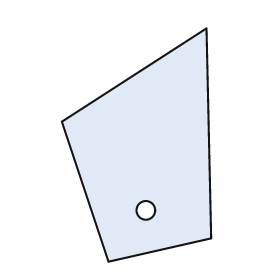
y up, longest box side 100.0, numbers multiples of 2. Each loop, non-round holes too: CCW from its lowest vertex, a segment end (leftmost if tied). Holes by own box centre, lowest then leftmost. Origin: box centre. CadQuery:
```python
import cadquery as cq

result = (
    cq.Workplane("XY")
    .moveTo(-12.0, -50.0)
    .lineTo(32.0, -40.0)
    .lineTo(30.0, 50.0)
    .lineTo(-32.0, 10.0)
    .close()
    .moveTo(4.0, -28.0)
    .circle(4.0)
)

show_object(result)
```